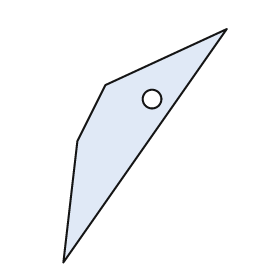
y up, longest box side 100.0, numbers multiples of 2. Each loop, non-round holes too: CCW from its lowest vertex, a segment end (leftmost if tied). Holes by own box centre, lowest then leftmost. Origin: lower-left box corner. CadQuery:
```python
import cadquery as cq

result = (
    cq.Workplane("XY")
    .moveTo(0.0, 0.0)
    .lineTo(70.0, 100.0)
    .lineTo(18.0, 76.0)
    .lineTo(6.0, 52.0)
    .close()
    .moveTo(38.0, 70.0)
    .circle(4.0)
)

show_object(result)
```